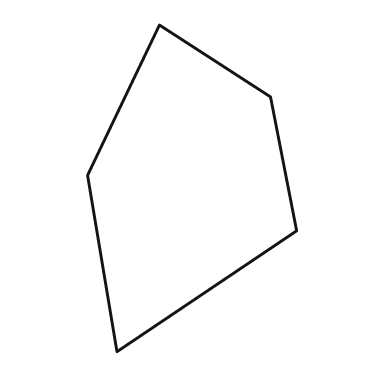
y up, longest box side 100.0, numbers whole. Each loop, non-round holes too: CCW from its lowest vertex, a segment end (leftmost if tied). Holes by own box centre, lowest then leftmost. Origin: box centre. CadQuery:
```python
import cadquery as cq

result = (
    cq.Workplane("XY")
    .moveTo(-23.0, -50.0)
    .lineTo(32.0, -13.0)
    .lineTo(24.0, 28.0)
    .lineTo(-10.0, 50.0)
    .lineTo(-32.0, 4.0)
    .close()
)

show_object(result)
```